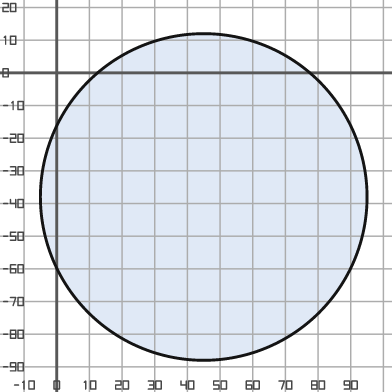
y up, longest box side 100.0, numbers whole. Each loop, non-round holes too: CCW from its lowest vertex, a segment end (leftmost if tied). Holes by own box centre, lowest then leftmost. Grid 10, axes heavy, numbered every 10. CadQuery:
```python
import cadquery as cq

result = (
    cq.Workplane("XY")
    .moveTo(45.0, -38.0)
    .circle(50.0)
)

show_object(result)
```